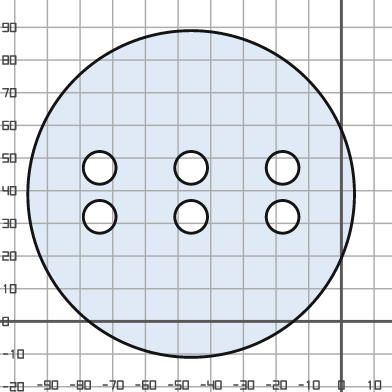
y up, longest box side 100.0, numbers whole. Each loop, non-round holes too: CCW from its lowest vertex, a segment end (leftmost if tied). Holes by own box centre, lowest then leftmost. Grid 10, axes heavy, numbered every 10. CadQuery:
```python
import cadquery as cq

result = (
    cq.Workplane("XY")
    .moveTo(-46.0, 39.0)
    .circle(50.0)
    .moveTo(-74.0, 32.0)
    .circle(5.0)
    .moveTo(-46.0, 32.0)
    .circle(5.0)
    .moveTo(-18.0, 32.0)
    .circle(5.0)
    .moveTo(-74.0, 47.0)
    .circle(5.0)
    .moveTo(-46.0, 47.0)
    .circle(5.0)
    .moveTo(-18.0, 47.0)
    .circle(5.0)
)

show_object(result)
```